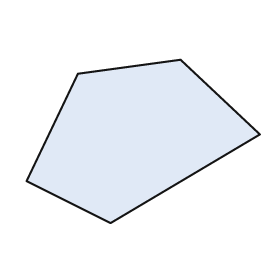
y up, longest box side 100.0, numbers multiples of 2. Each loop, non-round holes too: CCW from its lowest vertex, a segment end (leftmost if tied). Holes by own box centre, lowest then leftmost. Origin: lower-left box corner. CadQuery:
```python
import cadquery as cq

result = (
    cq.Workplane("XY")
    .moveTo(36.0, 0.0)
    .lineTo(100.0, 38.0)
    .lineTo(66.0, 70.0)
    .lineTo(22.0, 64.0)
    .lineTo(0.0, 18.0)
    .close()
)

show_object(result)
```